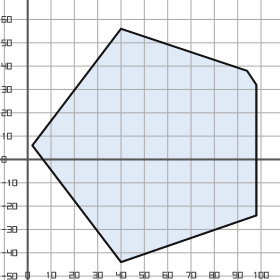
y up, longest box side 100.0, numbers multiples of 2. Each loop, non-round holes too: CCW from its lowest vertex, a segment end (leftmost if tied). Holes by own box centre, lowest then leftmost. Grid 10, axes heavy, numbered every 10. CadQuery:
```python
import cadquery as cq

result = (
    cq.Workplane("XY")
    .moveTo(40.0, -44.0)
    .lineTo(98.0, -24.0)
    .lineTo(98.0, 32.0)
    .lineTo(94.0, 38.0)
    .lineTo(40.0, 56.0)
    .lineTo(2.0, 6.0)
    .close()
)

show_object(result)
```